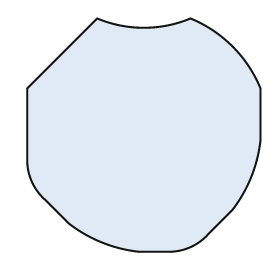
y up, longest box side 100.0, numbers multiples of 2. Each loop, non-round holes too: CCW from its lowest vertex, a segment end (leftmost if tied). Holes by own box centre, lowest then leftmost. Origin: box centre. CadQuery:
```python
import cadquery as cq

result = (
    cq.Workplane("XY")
    .moveTo(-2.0, -50.0)
    .lineTo(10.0, -50.0)
    .threePointArc((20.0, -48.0), (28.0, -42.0))
    .lineTo(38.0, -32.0)
    .threePointArc((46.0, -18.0), (50.0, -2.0))
    .lineTo(50.0, 20.0)
    .threePointArc((38.0, 38.0), (20.0, 50.0))
    .threePointArc((0.0, 46.0), (-20.0, 50.0))
    .lineTo(-50.0, 20.0)
    .lineTo(-50.0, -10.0)
    .threePointArc((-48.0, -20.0), (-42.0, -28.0))
    .lineTo(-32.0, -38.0)
    .threePointArc((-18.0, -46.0), (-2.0, -50.0))
    .close()
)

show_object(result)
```